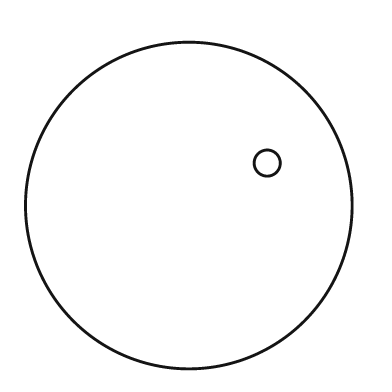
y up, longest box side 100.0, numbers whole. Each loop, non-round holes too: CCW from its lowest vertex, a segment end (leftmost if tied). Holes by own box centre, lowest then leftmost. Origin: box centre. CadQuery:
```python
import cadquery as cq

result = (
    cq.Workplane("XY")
    .moveTo(0.0, 0.0)
    .circle(50.0)
    .moveTo(24.0, 13.0)
    .circle(4.0)
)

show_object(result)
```